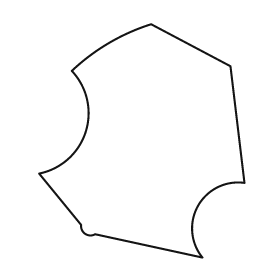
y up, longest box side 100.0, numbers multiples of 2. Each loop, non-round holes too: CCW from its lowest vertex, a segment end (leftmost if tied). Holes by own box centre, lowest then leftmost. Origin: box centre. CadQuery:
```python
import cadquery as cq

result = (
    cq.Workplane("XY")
    .moveTo(26.0, -50.0)
    .threePointArc((24.0, -28.0), (44.0, -18.0))
    .lineTo(38.0, 32.0)
    .lineTo(4.0, 50.0)
    .threePointArc((-14.0, 42.0), (-30.0, 30.0))
    .threePointArc((-24.0, 4.0), (-44.0, -14.0))
    .lineTo(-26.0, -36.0)
    .threePointArc((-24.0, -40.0), (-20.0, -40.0))
    .close()
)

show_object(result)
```